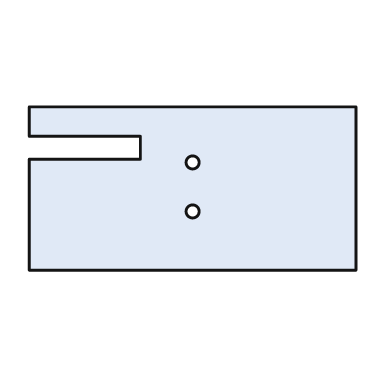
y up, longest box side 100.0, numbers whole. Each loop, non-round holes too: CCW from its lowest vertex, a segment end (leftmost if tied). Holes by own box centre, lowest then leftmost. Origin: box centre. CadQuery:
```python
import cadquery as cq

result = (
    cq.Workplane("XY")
    .moveTo(-50.0, -25.0)
    .lineTo(50.0, -25.0)
    .lineTo(50.0, 25.0)
    .lineTo(-50.0, 25.0)
    .lineTo(-50.0, 16.0)
    .lineTo(-16.0, 16.0)
    .lineTo(-16.0, 9.0)
    .lineTo(-50.0, 9.0)
    .close()
    .moveTo(0.0, -7.0)
    .circle(2.0)
    .moveTo(0.0, 8.0)
    .circle(2.0)
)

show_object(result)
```